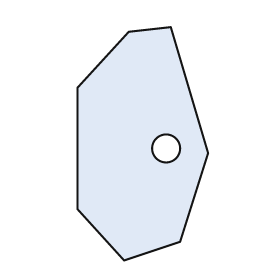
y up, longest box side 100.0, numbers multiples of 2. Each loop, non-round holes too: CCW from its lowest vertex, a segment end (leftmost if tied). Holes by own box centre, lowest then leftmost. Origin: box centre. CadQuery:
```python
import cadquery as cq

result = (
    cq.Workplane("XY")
    .moveTo(-8.0, -50.0)
    .lineTo(16.0, -42.0)
    .lineTo(28.0, -4.0)
    .lineTo(12.0, 50.0)
    .lineTo(-6.0, 48.0)
    .lineTo(-28.0, 24.0)
    .lineTo(-28.0, -28.0)
    .close()
    .moveTo(10.0, -2.0)
    .circle(6.0)
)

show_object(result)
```